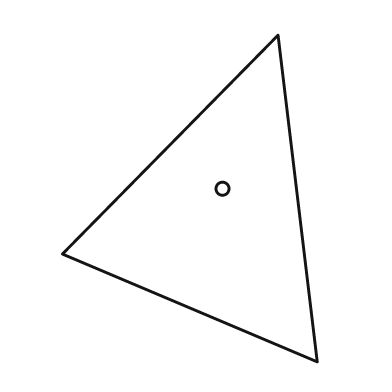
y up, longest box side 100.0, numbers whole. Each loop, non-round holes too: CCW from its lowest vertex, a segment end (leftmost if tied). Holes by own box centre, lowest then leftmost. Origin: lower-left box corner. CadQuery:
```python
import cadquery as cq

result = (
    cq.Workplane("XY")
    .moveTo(78.0, 0.0)
    .lineTo(66.0, 100.0)
    .lineTo(0.0, 33.0)
    .close()
    .moveTo(49.0, 53.0)
    .circle(2.0)
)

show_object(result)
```